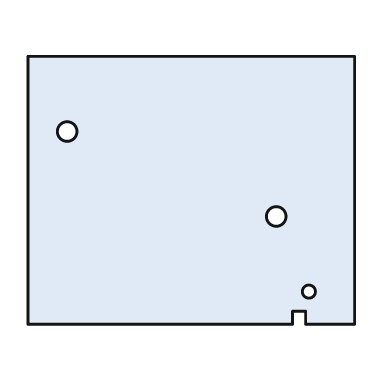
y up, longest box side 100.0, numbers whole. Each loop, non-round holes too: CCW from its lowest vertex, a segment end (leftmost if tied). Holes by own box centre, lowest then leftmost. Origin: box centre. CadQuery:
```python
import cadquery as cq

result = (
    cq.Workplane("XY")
    .moveTo(-50.0, -41.0)
    .lineTo(31.0, -41.0)
    .lineTo(31.0, -37.0)
    .lineTo(35.0, -37.0)
    .lineTo(35.0, -41.0)
    .lineTo(50.0, -41.0)
    .lineTo(50.0, 41.0)
    .lineTo(-50.0, 41.0)
    .close()
    .moveTo(36.0, -31.0)
    .circle(2.0)
    .moveTo(26.0, -8.0)
    .circle(3.0)
    .moveTo(-38.0, 18.0)
    .circle(3.0)
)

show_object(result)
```